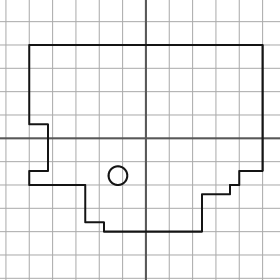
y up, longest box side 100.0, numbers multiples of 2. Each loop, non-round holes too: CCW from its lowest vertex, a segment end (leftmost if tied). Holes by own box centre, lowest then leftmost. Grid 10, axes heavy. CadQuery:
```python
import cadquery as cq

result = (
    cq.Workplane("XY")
    .moveTo(-18.0, -40.0)
    .lineTo(24.0, -40.0)
    .lineTo(24.0, -24.0)
    .lineTo(36.0, -24.0)
    .lineTo(36.0, -20.0)
    .lineTo(40.0, -20.0)
    .lineTo(40.0, -14.0)
    .lineTo(50.0, -14.0)
    .lineTo(50.0, 40.0)
    .lineTo(-50.0, 40.0)
    .lineTo(-50.0, 6.0)
    .lineTo(-42.0, 6.0)
    .lineTo(-42.0, -14.0)
    .lineTo(-50.0, -14.0)
    .lineTo(-50.0, -20.0)
    .lineTo(-26.0, -20.0)
    .lineTo(-26.0, -36.0)
    .lineTo(-18.0, -36.0)
    .close()
    .moveTo(-12.0, -16.0)
    .circle(4.0)
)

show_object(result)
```